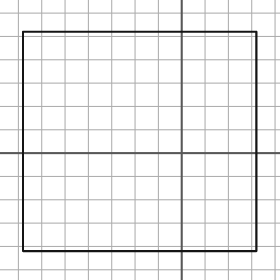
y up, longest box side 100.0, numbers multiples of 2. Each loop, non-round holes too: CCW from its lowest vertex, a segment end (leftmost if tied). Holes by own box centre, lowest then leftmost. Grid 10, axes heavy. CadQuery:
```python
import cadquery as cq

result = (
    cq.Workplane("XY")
    .moveTo(-68.0, -42.0)
    .lineTo(32.0, -42.0)
    .lineTo(32.0, 52.0)
    .lineTo(-68.0, 52.0)
    .close()
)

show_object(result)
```